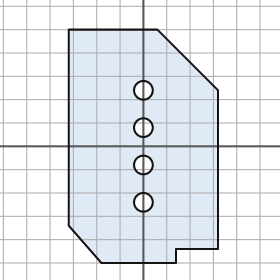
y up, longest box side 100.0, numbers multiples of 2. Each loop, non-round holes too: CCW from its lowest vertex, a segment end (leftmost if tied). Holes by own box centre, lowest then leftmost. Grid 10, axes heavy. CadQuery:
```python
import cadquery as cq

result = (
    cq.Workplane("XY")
    .moveTo(-18.0, -50.0)
    .lineTo(14.0, -50.0)
    .lineTo(14.0, -44.0)
    .lineTo(32.0, -44.0)
    .lineTo(32.0, 24.0)
    .lineTo(6.0, 50.0)
    .lineTo(-32.0, 50.0)
    .lineTo(-32.0, -34.0)
    .close()
    .moveTo(0.0, -24.0)
    .circle(4.0)
    .moveTo(0.0, -8.0)
    .circle(4.0)
    .moveTo(0.0, 8.0)
    .circle(4.0)
    .moveTo(0.0, 24.0)
    .circle(4.0)
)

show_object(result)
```